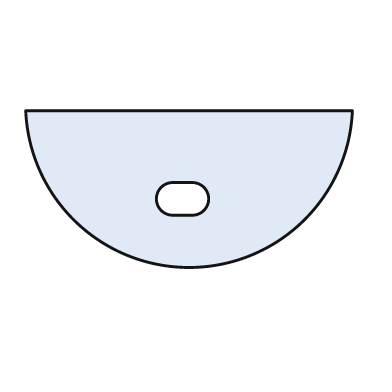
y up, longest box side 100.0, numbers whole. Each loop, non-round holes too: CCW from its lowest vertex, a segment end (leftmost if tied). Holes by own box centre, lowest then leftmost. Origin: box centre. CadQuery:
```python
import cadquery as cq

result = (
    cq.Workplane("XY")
    .moveTo(-50.0, 24.0)
    .threePointArc((0.0, -24.0), (50.0, 24.0))
    .close()
    .moveTo(-5.0, -8.0)
    .lineTo(1.0, -8.0)
    .threePointArc((6.0, -3.0), (1.0, 2.0))
    .lineTo(-5.0, 2.0)
    .threePointArc((-10.0, -3.0), (-5.0, -8.0))
    .close()
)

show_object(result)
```